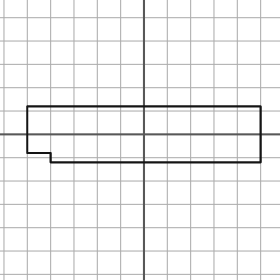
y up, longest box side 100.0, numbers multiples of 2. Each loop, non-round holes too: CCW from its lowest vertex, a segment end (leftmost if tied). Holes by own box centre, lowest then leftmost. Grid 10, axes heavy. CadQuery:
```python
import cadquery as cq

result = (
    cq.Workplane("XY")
    .moveTo(-40.0, -12.0)
    .lineTo(50.0, -12.0)
    .lineTo(50.0, 12.0)
    .lineTo(-50.0, 12.0)
    .lineTo(-50.0, -8.0)
    .lineTo(-40.0, -8.0)
    .close()
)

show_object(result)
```